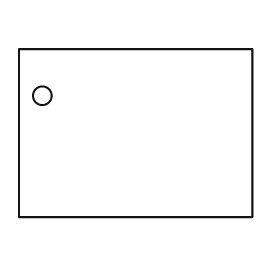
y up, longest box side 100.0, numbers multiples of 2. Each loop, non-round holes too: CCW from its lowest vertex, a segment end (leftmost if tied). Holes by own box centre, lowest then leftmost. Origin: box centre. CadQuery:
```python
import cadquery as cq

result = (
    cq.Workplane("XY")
    .moveTo(-50.0, -36.0)
    .lineTo(50.0, -36.0)
    .lineTo(50.0, 36.0)
    .lineTo(-50.0, 36.0)
    .close()
    .moveTo(-40.0, 16.0)
    .circle(4.0)
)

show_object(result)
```